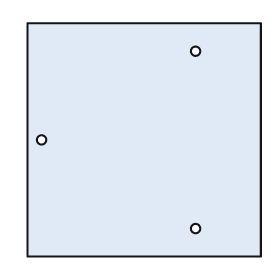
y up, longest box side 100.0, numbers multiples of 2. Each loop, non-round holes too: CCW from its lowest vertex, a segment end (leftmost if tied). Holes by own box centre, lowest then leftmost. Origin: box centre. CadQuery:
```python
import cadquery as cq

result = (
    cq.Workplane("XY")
    .moveTo(-50.0, -50.0)
    .lineTo(50.0, -50.0)
    .lineTo(50.0, 50.0)
    .lineTo(-50.0, 50.0)
    .close()
    .moveTo(22.0, -38.0)
    .circle(2.0)
    .moveTo(-44.0, 0.0)
    .circle(2.0)
    .moveTo(22.0, 38.0)
    .circle(2.0)
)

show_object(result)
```